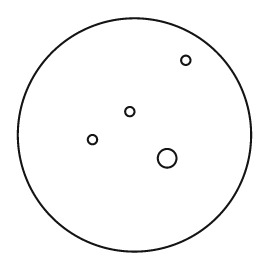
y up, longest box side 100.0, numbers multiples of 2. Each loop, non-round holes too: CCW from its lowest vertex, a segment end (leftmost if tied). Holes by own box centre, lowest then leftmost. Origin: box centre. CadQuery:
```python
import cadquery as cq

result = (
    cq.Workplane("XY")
    .moveTo(0.0, 0.0)
    .circle(50.0)
    .moveTo(14.0, -10.0)
    .circle(4.0)
    .moveTo(-18.0, -2.0)
    .circle(2.0)
    .moveTo(-2.0, 10.0)
    .circle(2.0)
    .moveTo(22.0, 32.0)
    .circle(2.0)
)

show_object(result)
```